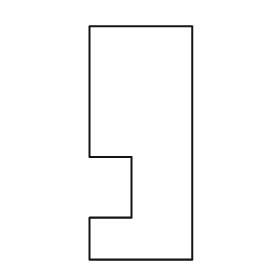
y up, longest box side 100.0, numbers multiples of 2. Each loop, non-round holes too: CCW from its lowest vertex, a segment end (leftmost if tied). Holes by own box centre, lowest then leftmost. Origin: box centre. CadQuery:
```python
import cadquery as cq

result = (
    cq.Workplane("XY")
    .moveTo(-22.0, -50.0)
    .lineTo(22.0, -50.0)
    .lineTo(22.0, 50.0)
    .lineTo(-22.0, 50.0)
    .lineTo(-22.0, -6.0)
    .lineTo(-4.0, -6.0)
    .lineTo(-4.0, -32.0)
    .lineTo(-22.0, -32.0)
    .close()
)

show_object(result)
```